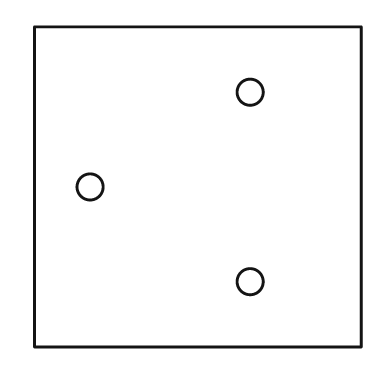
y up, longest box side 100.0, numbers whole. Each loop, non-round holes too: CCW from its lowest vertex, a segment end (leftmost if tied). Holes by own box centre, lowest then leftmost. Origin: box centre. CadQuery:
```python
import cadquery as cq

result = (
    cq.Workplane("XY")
    .moveTo(-50.0, -49.0)
    .lineTo(50.0, -49.0)
    .lineTo(50.0, 49.0)
    .lineTo(-50.0, 49.0)
    .close()
    .moveTo(16.0, -29.0)
    .circle(4.0)
    .moveTo(-33.0, 0.0)
    .circle(4.0)
    .moveTo(16.0, 29.0)
    .circle(4.0)
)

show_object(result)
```